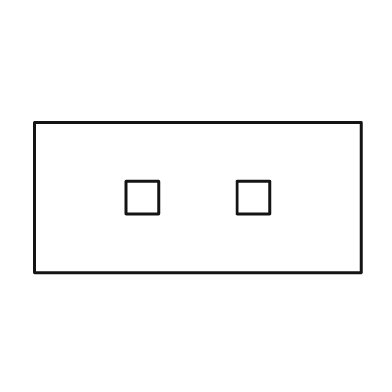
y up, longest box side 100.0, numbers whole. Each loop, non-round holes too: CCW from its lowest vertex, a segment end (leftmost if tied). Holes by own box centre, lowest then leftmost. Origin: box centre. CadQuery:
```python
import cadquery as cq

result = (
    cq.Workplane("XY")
    .moveTo(-50.0, -23.0)
    .lineTo(50.0, -23.0)
    .lineTo(50.0, 23.0)
    .lineTo(-50.0, 23.0)
    .close()
    .moveTo(-22.0, -5.0)
    .lineTo(-12.0, -5.0)
    .lineTo(-12.0, 5.0)
    .lineTo(-22.0, 5.0)
    .close()
    .moveTo(12.0, -5.0)
    .lineTo(22.0, -5.0)
    .lineTo(22.0, 5.0)
    .lineTo(12.0, 5.0)
    .close()
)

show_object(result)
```